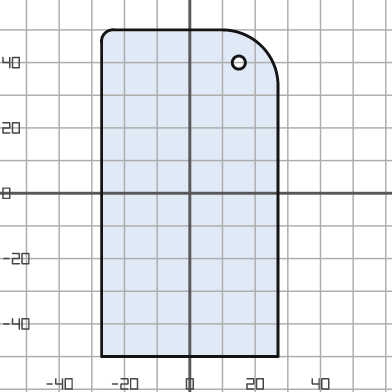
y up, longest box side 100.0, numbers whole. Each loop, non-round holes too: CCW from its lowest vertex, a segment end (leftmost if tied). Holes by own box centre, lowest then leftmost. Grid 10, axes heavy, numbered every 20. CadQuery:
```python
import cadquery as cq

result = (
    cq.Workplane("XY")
    .moveTo(-27.0, -50.0)
    .lineTo(27.0, -50.0)
    .lineTo(27.0, 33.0)
    .threePointArc((22.0, 45.0), (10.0, 50.0))
    .lineTo(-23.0, 50.0)
    .threePointArc((-26.0, 49.0), (-27.0, 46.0))
    .close()
    .moveTo(15.0, 40.0)
    .circle(2.0)
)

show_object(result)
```